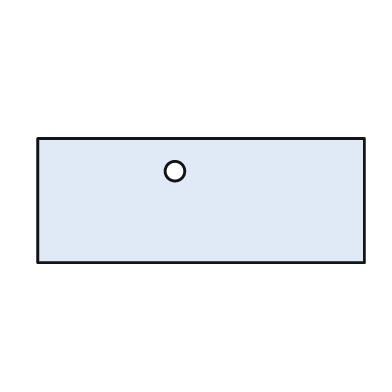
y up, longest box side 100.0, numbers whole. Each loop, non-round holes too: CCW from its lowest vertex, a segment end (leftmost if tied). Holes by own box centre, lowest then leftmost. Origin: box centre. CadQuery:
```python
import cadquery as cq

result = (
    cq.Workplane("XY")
    .moveTo(-50.0, -19.0)
    .lineTo(50.0, -19.0)
    .lineTo(50.0, 19.0)
    .lineTo(-50.0, 19.0)
    .close()
    .moveTo(-8.0, 9.0)
    .circle(3.0)
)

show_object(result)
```